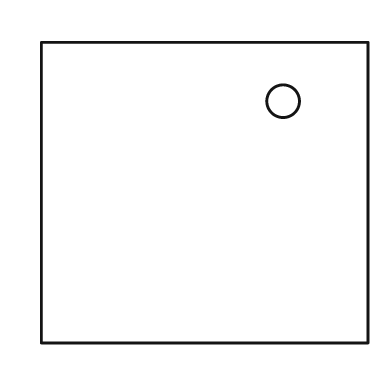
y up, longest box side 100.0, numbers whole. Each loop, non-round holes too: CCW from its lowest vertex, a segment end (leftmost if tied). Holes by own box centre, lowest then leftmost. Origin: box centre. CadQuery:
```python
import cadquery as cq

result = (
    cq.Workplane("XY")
    .moveTo(-50.0, -46.0)
    .lineTo(50.0, -46.0)
    .lineTo(50.0, 46.0)
    .lineTo(-50.0, 46.0)
    .close()
    .moveTo(24.0, 28.0)
    .circle(5.0)
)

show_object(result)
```